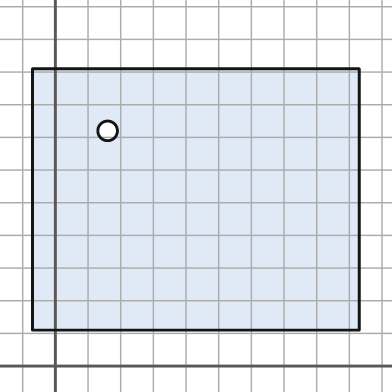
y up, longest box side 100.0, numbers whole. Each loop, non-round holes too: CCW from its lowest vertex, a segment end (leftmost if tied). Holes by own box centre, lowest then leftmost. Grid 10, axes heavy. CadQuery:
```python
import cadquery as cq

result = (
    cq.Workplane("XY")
    .moveTo(-7.0, 11.0)
    .lineTo(93.0, 11.0)
    .lineTo(93.0, 91.0)
    .lineTo(-7.0, 91.0)
    .close()
    .moveTo(16.0, 72.0)
    .circle(3.0)
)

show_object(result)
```